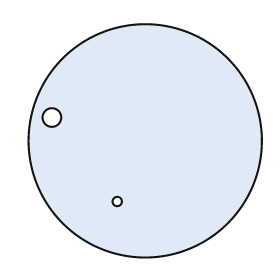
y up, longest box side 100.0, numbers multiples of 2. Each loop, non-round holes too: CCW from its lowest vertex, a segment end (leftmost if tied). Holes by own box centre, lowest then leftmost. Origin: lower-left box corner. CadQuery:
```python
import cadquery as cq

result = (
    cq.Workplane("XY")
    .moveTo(50.0, 50.0)
    .circle(50.0)
    .moveTo(38.0, 24.0)
    .circle(2.0)
    .moveTo(10.0, 60.0)
    .circle(4.0)
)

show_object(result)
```